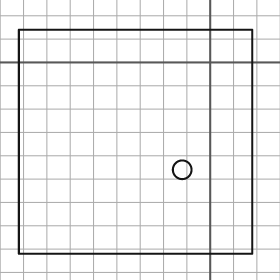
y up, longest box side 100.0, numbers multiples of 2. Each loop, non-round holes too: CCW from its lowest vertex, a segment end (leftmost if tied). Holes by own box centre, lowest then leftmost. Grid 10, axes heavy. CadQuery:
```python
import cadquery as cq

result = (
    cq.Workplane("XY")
    .moveTo(-82.0, -82.0)
    .lineTo(18.0, -82.0)
    .lineTo(18.0, 14.0)
    .lineTo(-82.0, 14.0)
    .close()
    .moveTo(-12.0, -46.0)
    .circle(4.0)
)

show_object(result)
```